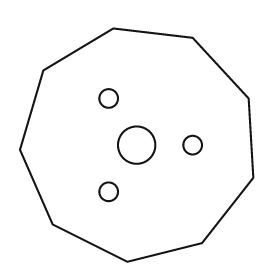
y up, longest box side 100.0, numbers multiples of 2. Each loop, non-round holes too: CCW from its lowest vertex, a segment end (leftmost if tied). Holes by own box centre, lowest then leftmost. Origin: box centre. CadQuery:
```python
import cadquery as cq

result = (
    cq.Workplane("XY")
    .moveTo(-4.0, -50.0)
    .lineTo(28.0, -42.0)
    .lineTo(50.0, -14.0)
    .lineTo(48.0, 20.0)
    .lineTo(24.0, 46.0)
    .lineTo(-10.0, 50.0)
    .lineTo(-40.0, 32.0)
    .lineTo(-50.0, -2.0)
    .lineTo(-36.0, -34.0)
    .close()
    .moveTo(-12.0, -20.0)
    .circle(4.0)
    .moveTo(0.0, 0.0)
    .circle(8.0)
    .moveTo(24.0, 0.0)
    .circle(4.0)
    .moveTo(-12.0, 20.0)
    .circle(4.0)
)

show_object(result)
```